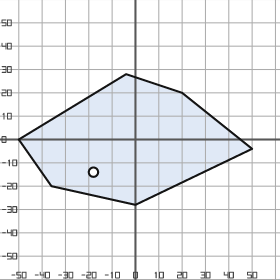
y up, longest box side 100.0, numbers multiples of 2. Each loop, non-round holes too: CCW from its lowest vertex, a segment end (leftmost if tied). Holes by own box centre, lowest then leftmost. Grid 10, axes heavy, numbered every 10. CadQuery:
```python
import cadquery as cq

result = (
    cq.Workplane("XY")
    .moveTo(0.0, -28.0)
    .lineTo(50.0, -4.0)
    .lineTo(20.0, 20.0)
    .lineTo(-4.0, 28.0)
    .lineTo(-50.0, 0.0)
    .lineTo(-36.0, -20.0)
    .close()
    .moveTo(-18.0, -14.0)
    .circle(2.0)
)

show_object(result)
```